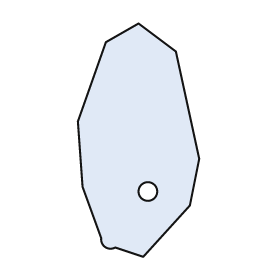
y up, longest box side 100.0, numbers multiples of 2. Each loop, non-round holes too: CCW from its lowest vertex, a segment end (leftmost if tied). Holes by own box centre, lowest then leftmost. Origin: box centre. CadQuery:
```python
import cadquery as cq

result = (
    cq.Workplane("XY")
    .moveTo(2.0, -50.0)
    .lineTo(22.0, -28.0)
    .lineTo(26.0, -8.0)
    .lineTo(16.0, 38.0)
    .lineTo(0.0, 50.0)
    .lineTo(-14.0, 42.0)
    .lineTo(-26.0, 8.0)
    .lineTo(-24.0, -20.0)
    .lineTo(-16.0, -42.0)
    .threePointArc((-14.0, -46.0), (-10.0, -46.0))
    .close()
    .moveTo(4.0, -22.0)
    .circle(4.0)
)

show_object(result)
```